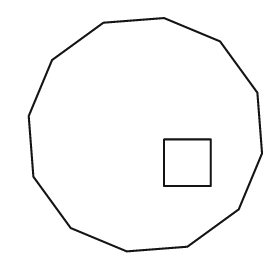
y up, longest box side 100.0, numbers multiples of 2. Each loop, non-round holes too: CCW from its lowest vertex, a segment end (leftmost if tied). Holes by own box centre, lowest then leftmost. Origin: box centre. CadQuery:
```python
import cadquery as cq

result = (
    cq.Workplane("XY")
    .moveTo(-8.0, -50.0)
    .lineTo(18.0, -48.0)
    .lineTo(40.0, -32.0)
    .lineTo(50.0, -8.0)
    .lineTo(48.0, 18.0)
    .lineTo(32.0, 40.0)
    .lineTo(8.0, 50.0)
    .lineTo(-18.0, 48.0)
    .lineTo(-40.0, 32.0)
    .lineTo(-50.0, 8.0)
    .lineTo(-48.0, -18.0)
    .lineTo(-32.0, -40.0)
    .close()
    .moveTo(8.0, -22.0)
    .lineTo(28.0, -22.0)
    .lineTo(28.0, -2.0)
    .lineTo(8.0, -2.0)
    .close()
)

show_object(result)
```